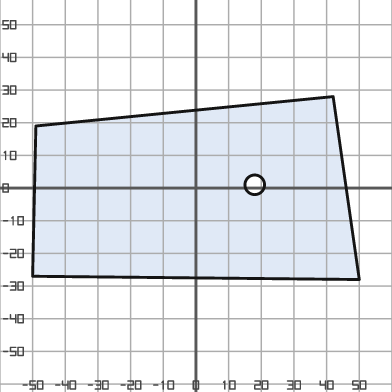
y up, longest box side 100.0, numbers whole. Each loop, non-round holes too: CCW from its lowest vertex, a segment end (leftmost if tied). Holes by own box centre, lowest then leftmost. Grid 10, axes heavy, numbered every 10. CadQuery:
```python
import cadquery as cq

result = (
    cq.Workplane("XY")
    .moveTo(50.0, -28.0)
    .lineTo(42.0, 28.0)
    .lineTo(-49.0, 19.0)
    .lineTo(-50.0, -27.0)
    .close()
    .moveTo(18.0, 1.0)
    .circle(3.0)
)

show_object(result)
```